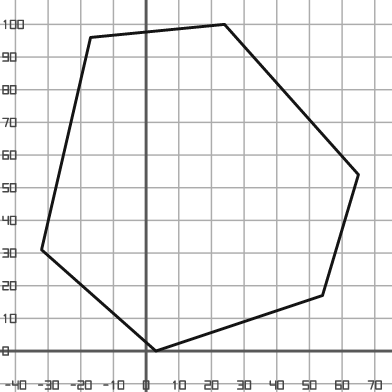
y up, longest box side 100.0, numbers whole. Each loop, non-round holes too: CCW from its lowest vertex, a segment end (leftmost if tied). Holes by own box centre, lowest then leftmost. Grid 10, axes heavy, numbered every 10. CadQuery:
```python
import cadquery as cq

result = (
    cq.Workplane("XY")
    .moveTo(3.0, 0.0)
    .lineTo(54.0, 17.0)
    .lineTo(65.0, 54.0)
    .lineTo(24.0, 100.0)
    .lineTo(-17.0, 96.0)
    .lineTo(-32.0, 31.0)
    .close()
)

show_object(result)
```